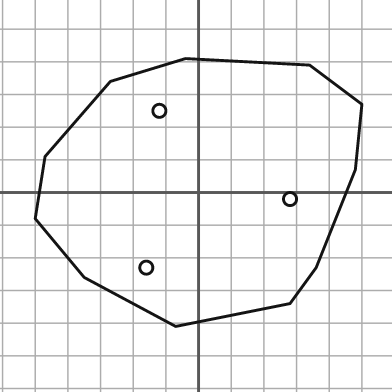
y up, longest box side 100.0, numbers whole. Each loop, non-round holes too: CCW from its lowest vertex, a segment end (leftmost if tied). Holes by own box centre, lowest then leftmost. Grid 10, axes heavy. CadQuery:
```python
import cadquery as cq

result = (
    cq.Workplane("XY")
    .moveTo(-7.0, -41.0)
    .lineTo(28.0, -34.0)
    .lineTo(36.0, -23.0)
    .lineTo(48.0, 7.0)
    .lineTo(50.0, 27.0)
    .lineTo(34.0, 39.0)
    .lineTo(-4.0, 41.0)
    .lineTo(-27.0, 34.0)
    .lineTo(-47.0, 11.0)
    .lineTo(-50.0, -8.0)
    .lineTo(-35.0, -26.0)
    .close()
    .moveTo(-16.0, -23.0)
    .circle(2.0)
    .moveTo(28.0, -2.0)
    .circle(2.0)
    .moveTo(-12.0, 25.0)
    .circle(2.0)
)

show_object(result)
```